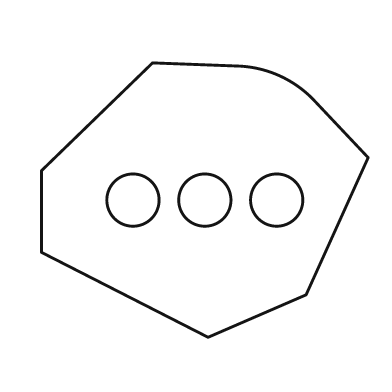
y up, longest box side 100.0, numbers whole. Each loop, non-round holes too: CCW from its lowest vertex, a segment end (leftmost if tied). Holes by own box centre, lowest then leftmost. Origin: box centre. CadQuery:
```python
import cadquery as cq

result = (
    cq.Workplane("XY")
    .moveTo(1.0, -42.0)
    .lineTo(31.0, -29.0)
    .lineTo(50.0, 13.0)
    .lineTo(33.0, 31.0)
    .threePointArc((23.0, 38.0), (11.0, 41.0))
    .lineTo(-16.0, 42.0)
    .lineTo(-50.0, 9.0)
    .lineTo(-50.0, -16.0)
    .close()
    .moveTo(-22.0, 0.0)
    .circle(8.0)
    .moveTo(0.0, 0.0)
    .circle(8.0)
    .moveTo(22.0, 0.0)
    .circle(8.0)
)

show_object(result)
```